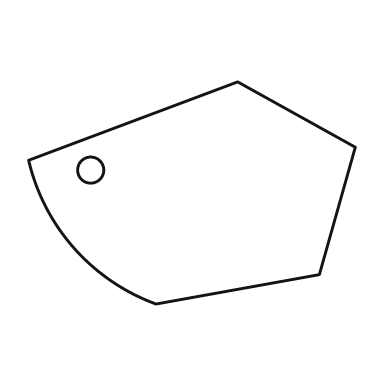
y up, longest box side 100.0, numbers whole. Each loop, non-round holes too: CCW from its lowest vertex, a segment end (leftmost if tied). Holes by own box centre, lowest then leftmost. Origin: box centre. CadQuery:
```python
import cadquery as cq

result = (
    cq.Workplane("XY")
    .moveTo(-11.0, -34.0)
    .lineTo(39.0, -25.0)
    .lineTo(50.0, 14.0)
    .lineTo(14.0, 34.0)
    .lineTo(-50.0, 10.0)
    .threePointArc((-36.0, -17.0), (-11.0, -34.0))
    .close()
    .moveTo(-31.0, 7.0)
    .circle(4.0)
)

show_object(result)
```